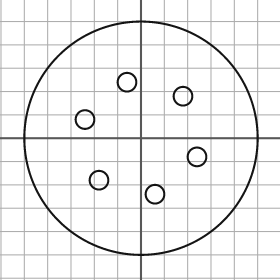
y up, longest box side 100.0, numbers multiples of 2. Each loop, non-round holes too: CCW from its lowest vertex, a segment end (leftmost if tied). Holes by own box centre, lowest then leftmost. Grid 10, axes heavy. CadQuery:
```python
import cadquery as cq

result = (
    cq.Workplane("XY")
    .moveTo(0.0, 0.0)
    .circle(50.0)
    .moveTo(6.0, -24.0)
    .circle(4.0)
    .moveTo(-18.0, -18.0)
    .circle(4.0)
    .moveTo(24.0, -8.0)
    .circle(4.0)
    .moveTo(-24.0, 8.0)
    .circle(4.0)
    .moveTo(18.0, 18.0)
    .circle(4.0)
    .moveTo(-6.0, 24.0)
    .circle(4.0)
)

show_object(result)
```